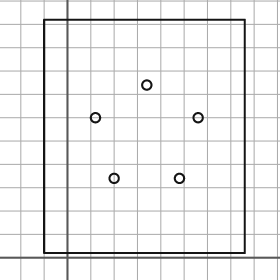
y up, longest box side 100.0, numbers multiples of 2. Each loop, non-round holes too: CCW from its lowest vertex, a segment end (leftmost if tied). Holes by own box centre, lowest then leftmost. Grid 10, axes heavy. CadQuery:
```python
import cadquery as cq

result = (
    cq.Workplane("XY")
    .moveTo(-10.0, 2.0)
    .lineTo(76.0, 2.0)
    .lineTo(76.0, 102.0)
    .lineTo(-10.0, 102.0)
    .close()
    .moveTo(20.0, 34.0)
    .circle(2.0)
    .moveTo(48.0, 34.0)
    .circle(2.0)
    .moveTo(12.0, 60.0)
    .circle(2.0)
    .moveTo(56.0, 60.0)
    .circle(2.0)
    .moveTo(34.0, 74.0)
    .circle(2.0)
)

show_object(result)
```